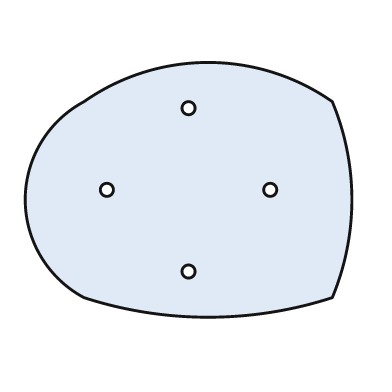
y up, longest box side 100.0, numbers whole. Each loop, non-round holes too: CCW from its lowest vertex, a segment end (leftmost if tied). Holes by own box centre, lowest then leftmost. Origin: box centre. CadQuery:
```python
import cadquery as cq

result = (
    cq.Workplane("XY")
    .moveTo(-32.0, -33.0)
    .threePointArc((6.0, -39.0), (44.0, -33.0))
    .threePointArc((50.0, -3.0), (44.0, 27.0))
    .threePointArc((6.0, 39.0), (-32.0, 27.0))
    .threePointArc((-50.0, -3.0), (-32.0, -33.0))
    .close()
    .moveTo(0.0, -25.0)
    .circle(2.0)
    .moveTo(-25.0, 0.0)
    .circle(2.0)
    .moveTo(25.0, 0.0)
    .circle(2.0)
    .moveTo(0.0, 25.0)
    .circle(2.0)
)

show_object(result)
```